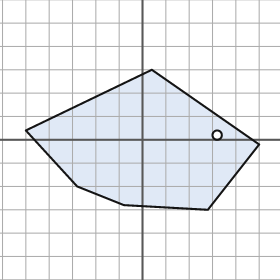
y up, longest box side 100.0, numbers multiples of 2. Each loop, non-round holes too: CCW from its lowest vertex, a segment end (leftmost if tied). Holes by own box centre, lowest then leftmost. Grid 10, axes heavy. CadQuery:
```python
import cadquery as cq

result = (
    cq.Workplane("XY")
    .moveTo(28.0, -30.0)
    .lineTo(50.0, -2.0)
    .lineTo(4.0, 30.0)
    .lineTo(-50.0, 4.0)
    .lineTo(-28.0, -20.0)
    .lineTo(-8.0, -28.0)
    .close()
    .moveTo(32.0, 2.0)
    .circle(2.0)
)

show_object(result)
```